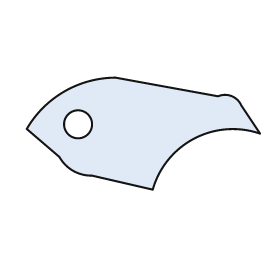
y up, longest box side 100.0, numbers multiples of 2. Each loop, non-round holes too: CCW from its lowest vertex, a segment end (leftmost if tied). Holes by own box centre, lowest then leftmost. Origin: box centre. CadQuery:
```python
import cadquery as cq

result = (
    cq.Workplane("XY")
    .moveTo(4.0, -24.0)
    .threePointArc((22.0, -2.0), (50.0, 0.0))
    .lineTo(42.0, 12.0)
    .threePointArc((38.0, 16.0), (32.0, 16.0))
    .lineTo(-12.0, 24.0)
    .threePointArc((-34.0, 18.0), (-50.0, 2.0))
    .lineTo(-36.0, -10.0)
    .threePointArc((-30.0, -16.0), (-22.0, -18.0))
    .close()
    .moveTo(-28.0, 4.0)
    .circle(6.0)
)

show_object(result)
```